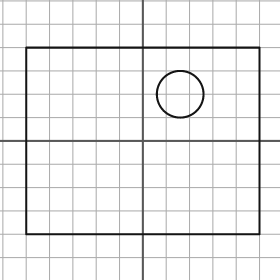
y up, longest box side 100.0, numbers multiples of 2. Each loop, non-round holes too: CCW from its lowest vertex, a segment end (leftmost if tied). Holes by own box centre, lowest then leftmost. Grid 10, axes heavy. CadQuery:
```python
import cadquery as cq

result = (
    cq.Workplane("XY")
    .moveTo(-50.0, -40.0)
    .lineTo(50.0, -40.0)
    .lineTo(50.0, 40.0)
    .lineTo(-50.0, 40.0)
    .close()
    .moveTo(16.0, 20.0)
    .circle(10.0)
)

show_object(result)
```